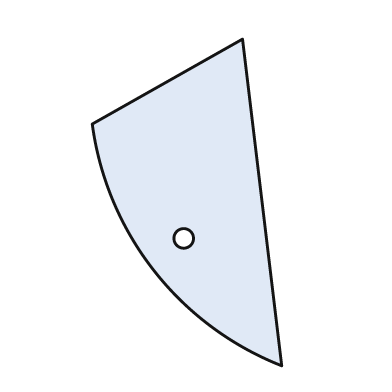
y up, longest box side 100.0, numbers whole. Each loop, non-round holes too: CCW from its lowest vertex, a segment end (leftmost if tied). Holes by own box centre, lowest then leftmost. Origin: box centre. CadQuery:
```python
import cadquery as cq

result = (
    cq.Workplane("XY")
    .moveTo(29.0, -50.0)
    .lineTo(17.0, 50.0)
    .lineTo(-29.0, 24.0)
    .threePointArc((-10.0, -21.0), (29.0, -50.0))
    .close()
    .moveTo(-1.0, -11.0)
    .circle(3.0)
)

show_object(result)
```